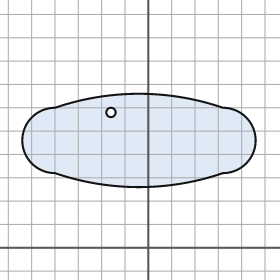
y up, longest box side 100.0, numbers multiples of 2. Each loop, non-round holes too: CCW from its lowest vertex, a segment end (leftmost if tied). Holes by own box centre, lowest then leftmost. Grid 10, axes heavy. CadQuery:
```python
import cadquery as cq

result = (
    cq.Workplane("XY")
    .moveTo(-40.0, 32.0)
    .threePointArc((-4.0, 26.0), (32.0, 32.0))
    .threePointArc((46.0, 46.0), (32.0, 60.0))
    .threePointArc((-4.0, 66.0), (-40.0, 60.0))
    .threePointArc((-54.0, 46.0), (-40.0, 32.0))
    .close()
    .moveTo(-16.0, 58.0)
    .circle(2.0)
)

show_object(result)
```